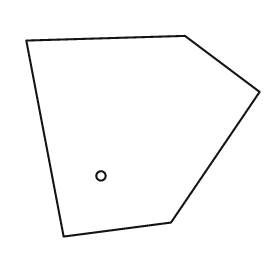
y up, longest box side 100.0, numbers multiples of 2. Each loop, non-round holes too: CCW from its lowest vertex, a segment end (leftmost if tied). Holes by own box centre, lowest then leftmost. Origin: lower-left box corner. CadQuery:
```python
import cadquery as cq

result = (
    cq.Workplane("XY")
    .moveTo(16.0, 0.0)
    .lineTo(62.0, 6.0)
    .lineTo(100.0, 62.0)
    .lineTo(68.0, 86.0)
    .lineTo(0.0, 84.0)
    .close()
    .moveTo(32.0, 26.0)
    .circle(2.0)
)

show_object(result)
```